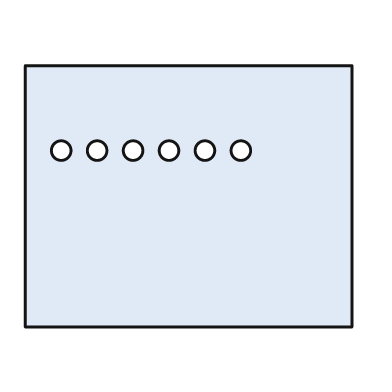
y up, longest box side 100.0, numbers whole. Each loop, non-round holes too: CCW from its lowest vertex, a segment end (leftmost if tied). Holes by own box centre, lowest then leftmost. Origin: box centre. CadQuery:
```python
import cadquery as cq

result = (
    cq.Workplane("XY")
    .moveTo(-50.0, -40.0)
    .lineTo(50.0, -40.0)
    .lineTo(50.0, 40.0)
    .lineTo(-50.0, 40.0)
    .close()
    .moveTo(-39.0, 14.0)
    .circle(3.0)
    .moveTo(-28.0, 14.0)
    .circle(3.0)
    .moveTo(-17.0, 14.0)
    .circle(3.0)
    .moveTo(-6.0, 14.0)
    .circle(3.0)
    .moveTo(5.0, 14.0)
    .circle(3.0)
    .moveTo(16.0, 14.0)
    .circle(3.0)
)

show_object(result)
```